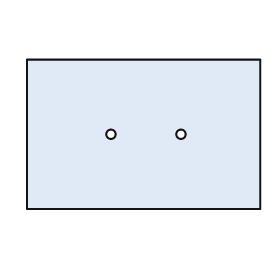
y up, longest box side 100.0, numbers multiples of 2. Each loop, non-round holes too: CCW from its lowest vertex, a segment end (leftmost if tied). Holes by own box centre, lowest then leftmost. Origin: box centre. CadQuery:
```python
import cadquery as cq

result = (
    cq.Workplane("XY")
    .moveTo(-50.0, -32.0)
    .lineTo(50.0, -32.0)
    .lineTo(50.0, 32.0)
    .lineTo(-50.0, 32.0)
    .close()
    .moveTo(-14.0, 0.0)
    .circle(2.0)
    .moveTo(16.0, 0.0)
    .circle(2.0)
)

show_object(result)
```